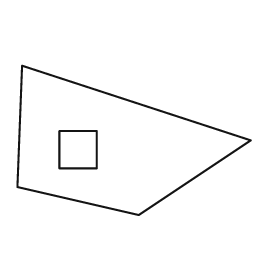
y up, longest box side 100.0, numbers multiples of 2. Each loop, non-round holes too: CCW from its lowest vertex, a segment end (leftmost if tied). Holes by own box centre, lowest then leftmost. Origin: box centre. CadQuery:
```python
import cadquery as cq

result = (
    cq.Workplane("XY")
    .moveTo(2.0, -32.0)
    .lineTo(50.0, 0.0)
    .lineTo(-48.0, 32.0)
    .lineTo(-50.0, -20.0)
    .close()
    .moveTo(-32.0, -12.0)
    .lineTo(-16.0, -12.0)
    .lineTo(-16.0, 4.0)
    .lineTo(-32.0, 4.0)
    .close()
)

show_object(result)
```